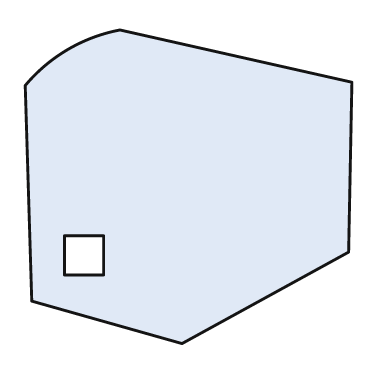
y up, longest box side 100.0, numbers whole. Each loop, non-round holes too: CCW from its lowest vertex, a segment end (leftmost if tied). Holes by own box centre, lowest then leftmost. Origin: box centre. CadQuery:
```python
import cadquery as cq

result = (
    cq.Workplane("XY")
    .moveTo(-2.0, -48.0)
    .lineTo(49.0, -20.0)
    .lineTo(50.0, 32.0)
    .lineTo(-21.0, 48.0)
    .threePointArc((-37.0, 42.0), (-50.0, 31.0))
    .lineTo(-48.0, -35.0)
    .close()
    .moveTo(-38.0, -27.0)
    .lineTo(-26.0, -27.0)
    .lineTo(-26.0, -15.0)
    .lineTo(-38.0, -15.0)
    .close()
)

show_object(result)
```